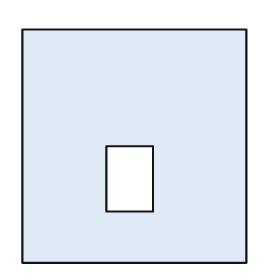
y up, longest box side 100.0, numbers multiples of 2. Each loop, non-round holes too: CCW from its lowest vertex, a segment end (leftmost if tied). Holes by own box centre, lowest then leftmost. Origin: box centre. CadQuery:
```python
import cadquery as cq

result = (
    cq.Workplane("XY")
    .moveTo(-48.0, -50.0)
    .lineTo(48.0, -50.0)
    .lineTo(48.0, 50.0)
    .lineTo(-48.0, 50.0)
    .close()
    .moveTo(-12.0, -28.0)
    .lineTo(8.0, -28.0)
    .lineTo(8.0, 0.0)
    .lineTo(-12.0, 0.0)
    .close()
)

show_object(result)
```